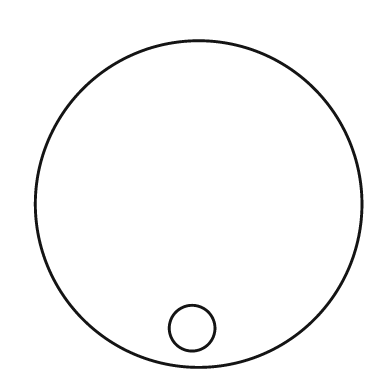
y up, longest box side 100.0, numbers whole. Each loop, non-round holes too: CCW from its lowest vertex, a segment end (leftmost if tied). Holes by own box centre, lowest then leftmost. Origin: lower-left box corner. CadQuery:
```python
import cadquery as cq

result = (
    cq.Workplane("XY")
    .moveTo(50.0, 50.0)
    .circle(50.0)
    .moveTo(48.0, 12.0)
    .circle(7.0)
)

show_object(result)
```